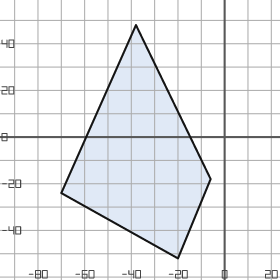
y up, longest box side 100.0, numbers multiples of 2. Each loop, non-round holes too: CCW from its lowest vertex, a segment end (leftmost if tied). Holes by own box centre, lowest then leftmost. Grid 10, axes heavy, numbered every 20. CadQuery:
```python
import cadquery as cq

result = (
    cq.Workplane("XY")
    .moveTo(-20.0, -52.0)
    .lineTo(-6.0, -18.0)
    .lineTo(-38.0, 48.0)
    .lineTo(-70.0, -24.0)
    .close()
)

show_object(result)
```